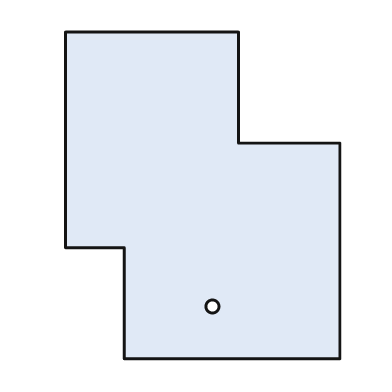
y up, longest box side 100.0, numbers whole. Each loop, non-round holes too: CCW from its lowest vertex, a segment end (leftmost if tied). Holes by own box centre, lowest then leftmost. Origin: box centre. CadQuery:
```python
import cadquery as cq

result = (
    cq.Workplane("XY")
    .moveTo(-24.0, -50.0)
    .lineTo(42.0, -50.0)
    .lineTo(42.0, 16.0)
    .lineTo(11.0, 16.0)
    .lineTo(11.0, 50.0)
    .lineTo(-42.0, 50.0)
    .lineTo(-42.0, -16.0)
    .lineTo(-24.0, -16.0)
    .close()
    .moveTo(3.0, -34.0)
    .circle(2.0)
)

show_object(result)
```